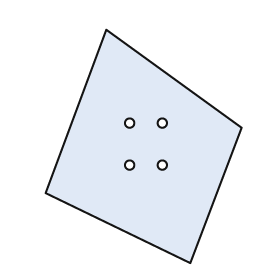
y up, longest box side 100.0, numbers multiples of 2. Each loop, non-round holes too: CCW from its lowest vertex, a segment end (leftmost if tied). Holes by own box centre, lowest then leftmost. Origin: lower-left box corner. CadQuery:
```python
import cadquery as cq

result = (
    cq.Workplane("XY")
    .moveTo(62.0, 0.0)
    .lineTo(84.0, 58.0)
    .lineTo(26.0, 100.0)
    .lineTo(0.0, 30.0)
    .close()
    .moveTo(36.0, 42.0)
    .circle(2.0)
    .moveTo(50.0, 42.0)
    .circle(2.0)
    .moveTo(36.0, 60.0)
    .circle(2.0)
    .moveTo(50.0, 60.0)
    .circle(2.0)
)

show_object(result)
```